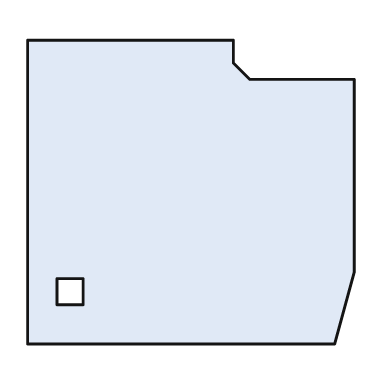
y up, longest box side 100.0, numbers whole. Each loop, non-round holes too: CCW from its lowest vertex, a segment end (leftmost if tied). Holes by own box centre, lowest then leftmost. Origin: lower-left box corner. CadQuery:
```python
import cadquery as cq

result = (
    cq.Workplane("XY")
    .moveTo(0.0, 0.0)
    .lineTo(94.0, 0.0)
    .lineTo(100.0, 22.0)
    .lineTo(100.0, 81.0)
    .lineTo(68.0, 81.0)
    .lineTo(63.0, 86.0)
    .lineTo(63.0, 93.0)
    .lineTo(0.0, 93.0)
    .close()
    .moveTo(9.0, 12.0)
    .lineTo(17.0, 12.0)
    .lineTo(17.0, 20.0)
    .lineTo(9.0, 20.0)
    .close()
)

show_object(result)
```